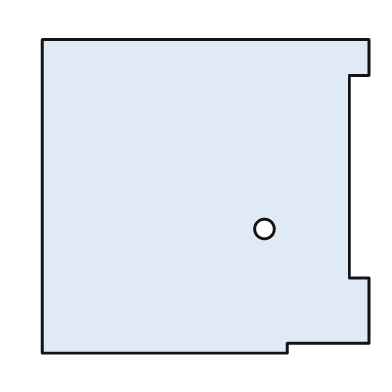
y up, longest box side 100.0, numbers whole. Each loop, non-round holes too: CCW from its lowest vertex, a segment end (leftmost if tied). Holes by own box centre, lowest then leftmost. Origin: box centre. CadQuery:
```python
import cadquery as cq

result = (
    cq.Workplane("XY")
    .moveTo(-50.0, -48.0)
    .lineTo(25.0, -48.0)
    .lineTo(25.0, -45.0)
    .lineTo(50.0, -45.0)
    .lineTo(50.0, -25.0)
    .lineTo(44.0, -25.0)
    .lineTo(44.0, 37.0)
    .lineTo(50.0, 37.0)
    .lineTo(50.0, 48.0)
    .lineTo(-50.0, 48.0)
    .close()
    .moveTo(18.0, -10.0)
    .circle(3.0)
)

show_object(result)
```